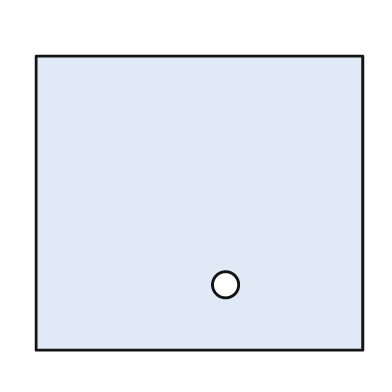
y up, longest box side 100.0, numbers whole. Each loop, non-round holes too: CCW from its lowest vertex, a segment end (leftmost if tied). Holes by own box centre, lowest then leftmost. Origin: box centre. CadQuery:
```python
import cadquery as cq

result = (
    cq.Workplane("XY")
    .moveTo(-50.0, -45.0)
    .lineTo(50.0, -45.0)
    .lineTo(50.0, 45.0)
    .lineTo(-50.0, 45.0)
    .close()
    .moveTo(8.0, -25.0)
    .circle(4.0)
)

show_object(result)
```